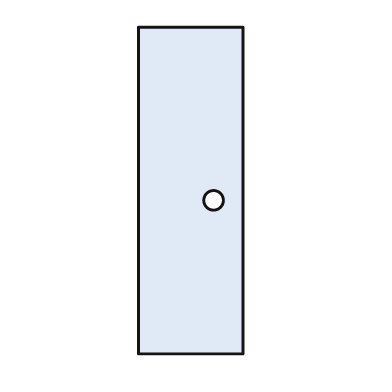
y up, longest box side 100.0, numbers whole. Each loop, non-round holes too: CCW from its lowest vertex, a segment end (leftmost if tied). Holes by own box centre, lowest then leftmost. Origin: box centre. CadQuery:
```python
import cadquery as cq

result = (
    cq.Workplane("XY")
    .moveTo(-16.0, -50.0)
    .lineTo(16.0, -50.0)
    .lineTo(16.0, 50.0)
    .lineTo(-16.0, 50.0)
    .close()
    .moveTo(7.0, -3.0)
    .circle(3.0)
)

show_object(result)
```